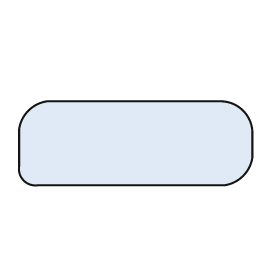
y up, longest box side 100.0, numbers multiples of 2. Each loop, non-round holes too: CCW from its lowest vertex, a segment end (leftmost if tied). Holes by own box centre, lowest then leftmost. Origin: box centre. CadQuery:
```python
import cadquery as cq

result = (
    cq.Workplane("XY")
    .moveTo(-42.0, -18.0)
    .lineTo(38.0, -18.0)
    .threePointArc((46.0, -14.0), (50.0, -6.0))
    .lineTo(50.0, 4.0)
    .threePointArc((46.0, 14.0), (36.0, 18.0))
    .lineTo(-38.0, 18.0)
    .threePointArc((-46.0, 14.0), (-50.0, 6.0))
    .lineTo(-50.0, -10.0)
    .threePointArc((-48.0, -16.0), (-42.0, -18.0))
    .close()
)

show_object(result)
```